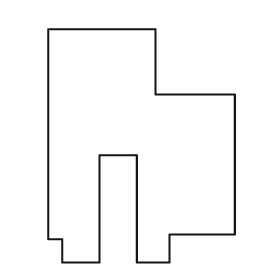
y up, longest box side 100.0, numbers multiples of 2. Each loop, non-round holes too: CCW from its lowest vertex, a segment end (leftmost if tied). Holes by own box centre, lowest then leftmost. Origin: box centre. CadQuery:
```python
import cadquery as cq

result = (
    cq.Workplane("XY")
    .moveTo(-34.0, -50.0)
    .lineTo(-18.0, -50.0)
    .lineTo(-18.0, -4.0)
    .lineTo(-2.0, -4.0)
    .lineTo(-2.0, -50.0)
    .lineTo(12.0, -50.0)
    .lineTo(12.0, -38.0)
    .lineTo(40.0, -38.0)
    .lineTo(40.0, 22.0)
    .lineTo(6.0, 22.0)
    .lineTo(6.0, 50.0)
    .lineTo(-40.0, 50.0)
    .lineTo(-40.0, -40.0)
    .lineTo(-34.0, -40.0)
    .close()
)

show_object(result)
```